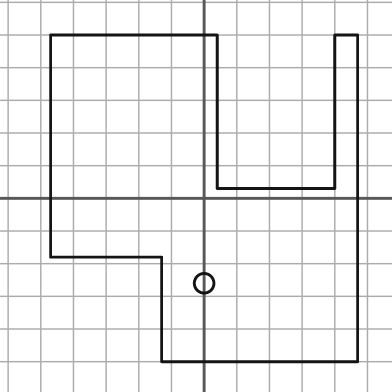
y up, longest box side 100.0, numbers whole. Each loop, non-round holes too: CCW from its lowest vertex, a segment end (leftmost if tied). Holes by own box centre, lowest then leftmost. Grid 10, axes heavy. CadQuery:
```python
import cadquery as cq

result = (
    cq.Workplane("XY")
    .moveTo(-13.0, -50.0)
    .lineTo(47.0, -50.0)
    .lineTo(47.0, 50.0)
    .lineTo(40.0, 50.0)
    .lineTo(40.0, 3.0)
    .lineTo(4.0, 3.0)
    .lineTo(4.0, 50.0)
    .lineTo(-47.0, 50.0)
    .lineTo(-47.0, -18.0)
    .lineTo(-13.0, -18.0)
    .close()
    .moveTo(0.0, -26.0)
    .circle(3.0)
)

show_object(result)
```